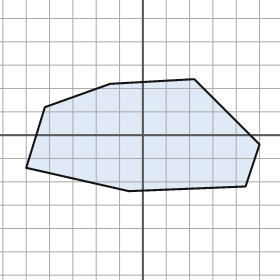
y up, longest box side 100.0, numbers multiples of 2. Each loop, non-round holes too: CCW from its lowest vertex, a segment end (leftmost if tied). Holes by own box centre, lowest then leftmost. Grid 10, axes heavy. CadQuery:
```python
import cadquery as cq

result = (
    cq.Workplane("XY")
    .moveTo(-6.0, -24.0)
    .lineTo(44.0, -22.0)
    .lineTo(50.0, -4.0)
    .lineTo(22.0, 24.0)
    .lineTo(-14.0, 22.0)
    .lineTo(-42.0, 12.0)
    .lineTo(-50.0, -14.0)
    .close()
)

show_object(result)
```